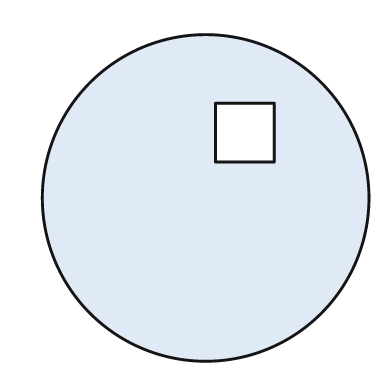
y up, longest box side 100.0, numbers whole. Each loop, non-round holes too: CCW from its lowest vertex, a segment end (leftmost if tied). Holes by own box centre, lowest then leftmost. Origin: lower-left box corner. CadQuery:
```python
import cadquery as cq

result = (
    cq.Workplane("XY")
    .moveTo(50.0, 50.0)
    .circle(50.0)
    .moveTo(53.0, 61.0)
    .lineTo(71.0, 61.0)
    .lineTo(71.0, 79.0)
    .lineTo(53.0, 79.0)
    .close()
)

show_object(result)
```